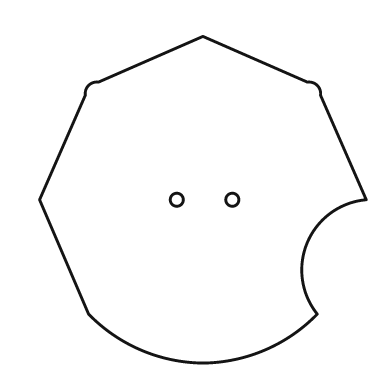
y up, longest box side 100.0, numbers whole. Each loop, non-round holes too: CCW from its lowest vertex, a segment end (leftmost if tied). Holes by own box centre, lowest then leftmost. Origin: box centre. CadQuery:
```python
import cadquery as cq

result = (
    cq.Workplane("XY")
    .moveTo(0.0, -50.0)
    .threePointArc((19.0, -46.0), (35.0, -35.0))
    .threePointArc((32.0, -13.0), (50.0, 0.0))
    .lineTo(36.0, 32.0)
    .threePointArc((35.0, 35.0), (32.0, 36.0))
    .lineTo(0.0, 50.0)
    .lineTo(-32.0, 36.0)
    .threePointArc((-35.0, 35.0), (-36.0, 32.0))
    .lineTo(-50.0, 0.0)
    .lineTo(-35.0, -35.0)
    .threePointArc((-19.0, -46.0), (0.0, -50.0))
    .close()
    .moveTo(-8.0, 0.0)
    .circle(2.0)
    .moveTo(9.0, 0.0)
    .circle(2.0)
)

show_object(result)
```